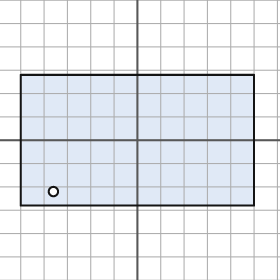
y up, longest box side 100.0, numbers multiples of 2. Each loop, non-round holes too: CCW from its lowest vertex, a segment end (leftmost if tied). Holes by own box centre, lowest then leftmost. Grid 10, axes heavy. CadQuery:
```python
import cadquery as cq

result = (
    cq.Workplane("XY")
    .moveTo(-50.0, -28.0)
    .lineTo(50.0, -28.0)
    .lineTo(50.0, 28.0)
    .lineTo(-50.0, 28.0)
    .close()
    .moveTo(-36.0, -22.0)
    .circle(2.0)
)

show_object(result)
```